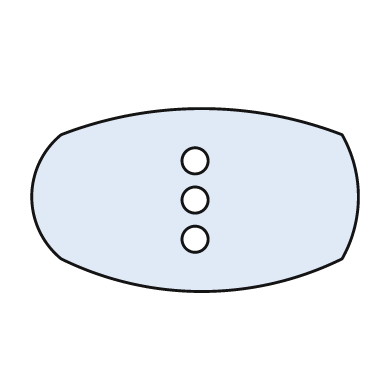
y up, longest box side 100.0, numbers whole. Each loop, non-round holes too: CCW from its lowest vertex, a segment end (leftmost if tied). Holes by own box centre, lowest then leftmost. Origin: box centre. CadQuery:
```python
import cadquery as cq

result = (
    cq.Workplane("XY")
    .moveTo(-41.0, -18.0)
    .threePointArc((2.0, -28.0), (45.0, -18.0))
    .threePointArc((50.0, 1.0), (45.0, 20.0))
    .threePointArc((2.0, 28.0), (-41.0, 20.0))
    .threePointArc((-50.0, 1.0), (-41.0, -18.0))
    .close()
    .moveTo(0.0, -12.0)
    .circle(4.0)
    .moveTo(0.0, 0.0)
    .circle(4.0)
    .moveTo(0.0, 12.0)
    .circle(4.0)
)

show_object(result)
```